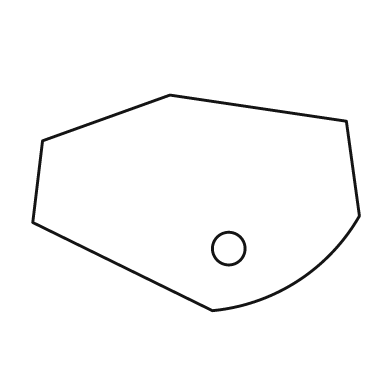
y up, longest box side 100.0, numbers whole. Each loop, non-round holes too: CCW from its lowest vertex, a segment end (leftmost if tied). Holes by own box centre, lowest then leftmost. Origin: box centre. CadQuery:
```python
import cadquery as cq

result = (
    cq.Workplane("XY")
    .moveTo(5.0, -33.0)
    .threePointArc((31.0, -24.0), (50.0, -4.0))
    .lineTo(46.0, 25.0)
    .lineTo(-8.0, 33.0)
    .lineTo(-47.0, 19.0)
    .lineTo(-50.0, -6.0)
    .close()
    .moveTo(10.0, -14.0)
    .circle(5.0)
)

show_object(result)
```